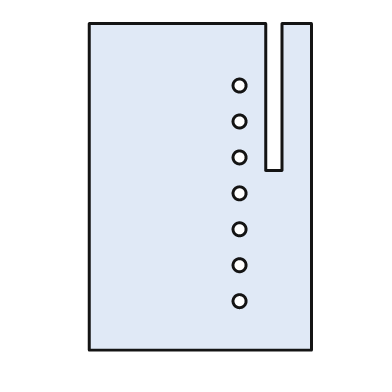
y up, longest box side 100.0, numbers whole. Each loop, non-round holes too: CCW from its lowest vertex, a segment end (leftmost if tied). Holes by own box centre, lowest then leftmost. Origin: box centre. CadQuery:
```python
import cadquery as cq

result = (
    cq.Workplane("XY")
    .moveTo(-34.0, -50.0)
    .lineTo(34.0, -50.0)
    .lineTo(34.0, 50.0)
    .lineTo(25.0, 50.0)
    .lineTo(25.0, 5.0)
    .lineTo(20.0, 5.0)
    .lineTo(20.0, 50.0)
    .lineTo(-34.0, 50.0)
    .close()
    .moveTo(12.0, -35.0)
    .circle(2.0)
    .moveTo(12.0, -24.0)
    .circle(2.0)
    .moveTo(12.0, -13.0)
    .circle(2.0)
    .moveTo(12.0, -2.0)
    .circle(2.0)
    .moveTo(12.0, 9.0)
    .circle(2.0)
    .moveTo(12.0, 20.0)
    .circle(2.0)
    .moveTo(12.0, 31.0)
    .circle(2.0)
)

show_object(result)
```